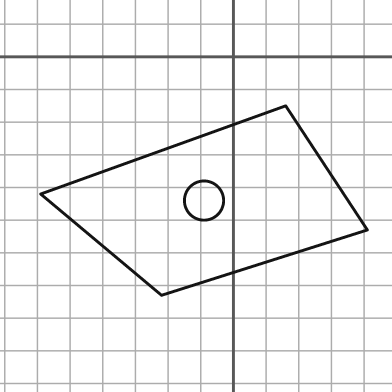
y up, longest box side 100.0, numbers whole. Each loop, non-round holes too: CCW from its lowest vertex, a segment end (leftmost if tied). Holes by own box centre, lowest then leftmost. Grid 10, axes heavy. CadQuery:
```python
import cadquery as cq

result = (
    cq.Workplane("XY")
    .moveTo(-22.0, -73.0)
    .lineTo(41.0, -53.0)
    .lineTo(16.0, -15.0)
    .lineTo(-59.0, -42.0)
    .close()
    .moveTo(-9.0, -44.0)
    .circle(6.0)
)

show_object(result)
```